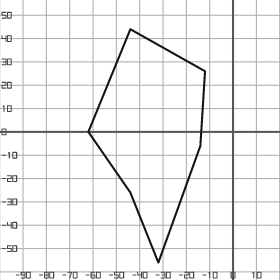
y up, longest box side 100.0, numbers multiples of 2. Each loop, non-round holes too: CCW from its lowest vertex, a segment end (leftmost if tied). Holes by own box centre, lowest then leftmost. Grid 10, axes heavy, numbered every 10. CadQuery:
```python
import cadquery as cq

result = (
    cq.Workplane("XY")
    .moveTo(-32.0, -56.0)
    .lineTo(-14.0, -6.0)
    .lineTo(-12.0, 26.0)
    .lineTo(-44.0, 44.0)
    .lineTo(-62.0, 0.0)
    .lineTo(-44.0, -26.0)
    .close()
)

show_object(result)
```